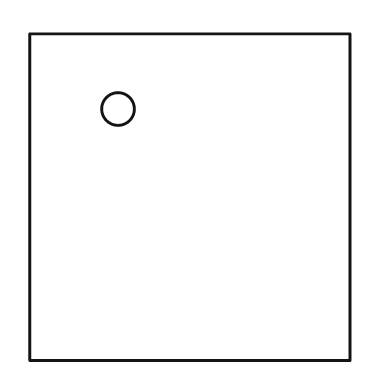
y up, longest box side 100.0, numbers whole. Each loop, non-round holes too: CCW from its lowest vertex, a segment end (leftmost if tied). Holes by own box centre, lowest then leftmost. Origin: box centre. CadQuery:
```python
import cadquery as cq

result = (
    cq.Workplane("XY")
    .moveTo(-49.0, -50.0)
    .lineTo(49.0, -50.0)
    .lineTo(49.0, 50.0)
    .lineTo(-49.0, 50.0)
    .close()
    .moveTo(-22.0, 27.0)
    .circle(5.0)
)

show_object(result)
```